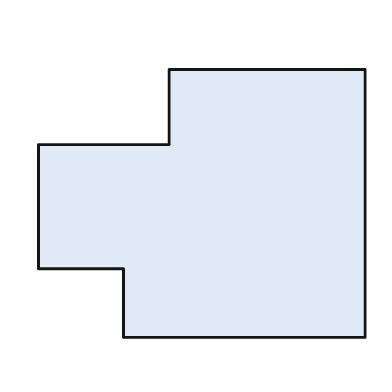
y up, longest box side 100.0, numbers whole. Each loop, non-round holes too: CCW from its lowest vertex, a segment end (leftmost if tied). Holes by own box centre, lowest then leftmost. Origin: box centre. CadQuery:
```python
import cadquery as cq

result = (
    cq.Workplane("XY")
    .moveTo(-24.0, -41.0)
    .lineTo(50.0, -41.0)
    .lineTo(50.0, 41.0)
    .lineTo(-10.0, 41.0)
    .lineTo(-10.0, 18.0)
    .lineTo(-50.0, 18.0)
    .lineTo(-50.0, -20.0)
    .lineTo(-24.0, -20.0)
    .close()
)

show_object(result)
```